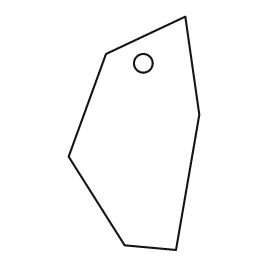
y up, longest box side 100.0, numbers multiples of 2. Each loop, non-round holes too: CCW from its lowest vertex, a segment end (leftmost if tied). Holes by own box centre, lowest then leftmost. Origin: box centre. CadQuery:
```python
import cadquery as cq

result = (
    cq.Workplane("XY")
    .moveTo(18.0, -50.0)
    .lineTo(28.0, 8.0)
    .lineTo(22.0, 50.0)
    .lineTo(-12.0, 34.0)
    .lineTo(-28.0, -10.0)
    .lineTo(-4.0, -48.0)
    .close()
    .moveTo(4.0, 30.0)
    .circle(4.0)
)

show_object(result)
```